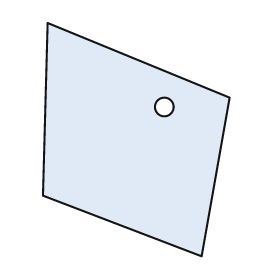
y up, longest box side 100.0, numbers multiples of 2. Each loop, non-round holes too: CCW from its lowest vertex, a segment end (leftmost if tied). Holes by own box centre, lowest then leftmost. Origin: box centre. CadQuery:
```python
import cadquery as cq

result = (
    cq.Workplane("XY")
    .moveTo(28.0, -50.0)
    .lineTo(40.0, 18.0)
    .lineTo(-38.0, 50.0)
    .lineTo(-40.0, -24.0)
    .close()
    .moveTo(12.0, 14.0)
    .circle(4.0)
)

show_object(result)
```